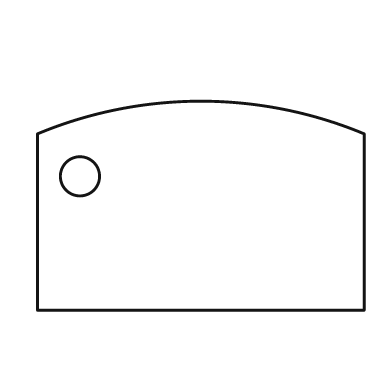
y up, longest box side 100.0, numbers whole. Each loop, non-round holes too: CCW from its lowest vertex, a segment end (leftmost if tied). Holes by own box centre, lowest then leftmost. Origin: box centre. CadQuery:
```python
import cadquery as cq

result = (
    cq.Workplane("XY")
    .moveTo(-50.0, -32.0)
    .lineTo(50.0, -32.0)
    .lineTo(50.0, 22.0)
    .threePointArc((0.0, 32.0), (-50.0, 22.0))
    .close()
    .moveTo(-37.0, 9.0)
    .circle(6.0)
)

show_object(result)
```